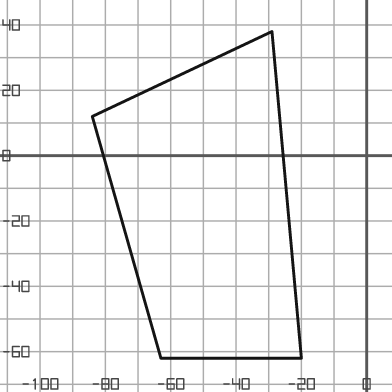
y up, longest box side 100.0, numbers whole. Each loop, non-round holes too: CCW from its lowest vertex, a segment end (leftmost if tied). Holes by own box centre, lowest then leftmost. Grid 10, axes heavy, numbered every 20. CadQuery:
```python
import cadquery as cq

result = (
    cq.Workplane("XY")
    .moveTo(-63.0, -62.0)
    .lineTo(-20.0, -62.0)
    .lineTo(-29.0, 38.0)
    .lineTo(-84.0, 12.0)
    .close()
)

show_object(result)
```